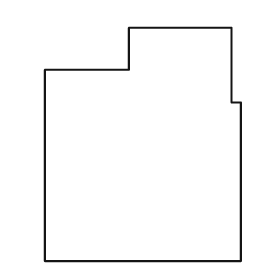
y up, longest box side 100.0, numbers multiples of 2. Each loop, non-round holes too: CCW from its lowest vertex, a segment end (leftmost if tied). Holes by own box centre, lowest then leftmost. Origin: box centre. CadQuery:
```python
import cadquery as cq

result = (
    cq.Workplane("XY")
    .moveTo(-42.0, -50.0)
    .lineTo(42.0, -50.0)
    .lineTo(42.0, 18.0)
    .lineTo(38.0, 18.0)
    .lineTo(38.0, 50.0)
    .lineTo(-6.0, 50.0)
    .lineTo(-6.0, 32.0)
    .lineTo(-42.0, 32.0)
    .close()
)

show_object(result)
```